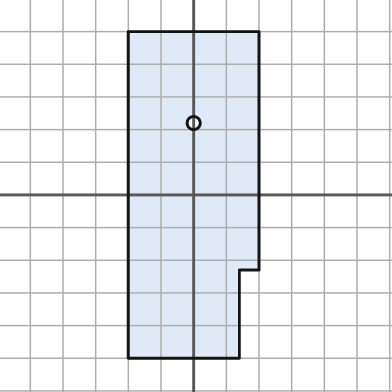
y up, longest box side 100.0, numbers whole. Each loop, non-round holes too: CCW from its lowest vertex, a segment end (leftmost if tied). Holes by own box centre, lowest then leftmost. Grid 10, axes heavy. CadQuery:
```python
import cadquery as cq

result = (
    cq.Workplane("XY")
    .moveTo(-20.0, -50.0)
    .lineTo(14.0, -50.0)
    .lineTo(14.0, -23.0)
    .lineTo(20.0, -23.0)
    .lineTo(20.0, 50.0)
    .lineTo(-20.0, 50.0)
    .close()
    .moveTo(0.0, 22.0)
    .circle(2.0)
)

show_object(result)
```